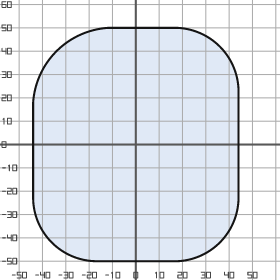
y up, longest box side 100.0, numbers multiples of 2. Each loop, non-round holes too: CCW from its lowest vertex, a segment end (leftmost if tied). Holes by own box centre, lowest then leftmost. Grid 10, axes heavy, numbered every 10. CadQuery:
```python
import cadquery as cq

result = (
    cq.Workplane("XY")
    .moveTo(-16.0, -50.0)
    .lineTo(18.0, -50.0)
    .threePointArc((36.0, -42.0), (44.0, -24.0))
    .lineTo(44.0, 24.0)
    .threePointArc((36.0, 42.0), (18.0, 50.0))
    .lineTo(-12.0, 50.0)
    .threePointArc((-34.0, 40.0), (-44.0, 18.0))
    .lineTo(-44.0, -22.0)
    .threePointArc((-36.0, -42.0), (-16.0, -50.0))
    .close()
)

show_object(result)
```